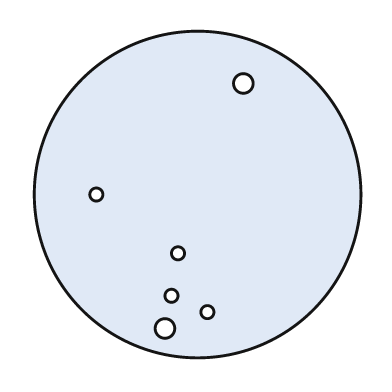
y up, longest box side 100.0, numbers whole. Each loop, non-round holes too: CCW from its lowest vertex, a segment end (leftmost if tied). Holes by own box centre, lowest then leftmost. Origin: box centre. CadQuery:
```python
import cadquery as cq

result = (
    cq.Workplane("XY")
    .moveTo(0.0, 0.0)
    .circle(50.0)
    .moveTo(-10.0, -41.0)
    .circle(3.0)
    .moveTo(3.0, -36.0)
    .circle(2.0)
    .moveTo(-8.0, -31.0)
    .circle(2.0)
    .moveTo(-6.0, -18.0)
    .circle(2.0)
    .moveTo(-31.0, 0.0)
    .circle(2.0)
    .moveTo(14.0, 34.0)
    .circle(3.0)
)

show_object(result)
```